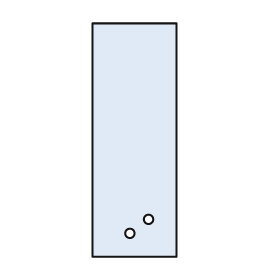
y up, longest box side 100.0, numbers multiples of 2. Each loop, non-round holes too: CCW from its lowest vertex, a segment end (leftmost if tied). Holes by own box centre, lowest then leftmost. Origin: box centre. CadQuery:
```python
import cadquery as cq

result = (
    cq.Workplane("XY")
    .moveTo(-18.0, -50.0)
    .lineTo(18.0, -50.0)
    .lineTo(18.0, 50.0)
    .lineTo(-18.0, 50.0)
    .close()
    .moveTo(-2.0, -40.0)
    .circle(2.0)
    .moveTo(6.0, -34.0)
    .circle(2.0)
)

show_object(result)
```